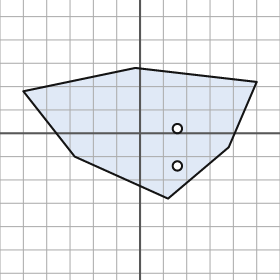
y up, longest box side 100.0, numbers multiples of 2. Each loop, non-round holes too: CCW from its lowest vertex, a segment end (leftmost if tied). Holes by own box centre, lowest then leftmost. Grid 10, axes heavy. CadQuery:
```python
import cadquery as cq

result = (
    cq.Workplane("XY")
    .moveTo(12.0, -28.0)
    .lineTo(38.0, -6.0)
    .lineTo(50.0, 22.0)
    .lineTo(-2.0, 28.0)
    .lineTo(-50.0, 18.0)
    .lineTo(-28.0, -10.0)
    .close()
    .moveTo(16.0, -14.0)
    .circle(2.0)
    .moveTo(16.0, 2.0)
    .circle(2.0)
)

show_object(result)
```